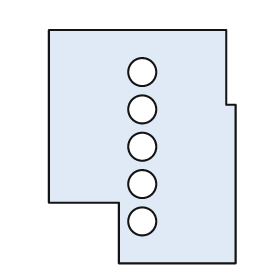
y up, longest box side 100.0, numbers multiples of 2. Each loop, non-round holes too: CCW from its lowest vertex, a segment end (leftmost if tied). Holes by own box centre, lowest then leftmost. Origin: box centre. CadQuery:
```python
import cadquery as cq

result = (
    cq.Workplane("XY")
    .moveTo(-10.0, -50.0)
    .lineTo(40.0, -50.0)
    .lineTo(40.0, 18.0)
    .lineTo(36.0, 18.0)
    .lineTo(36.0, 50.0)
    .lineTo(-40.0, 50.0)
    .lineTo(-40.0, -24.0)
    .lineTo(-10.0, -24.0)
    .close()
    .moveTo(0.0, -32.0)
    .circle(6.0)
    .moveTo(0.0, -16.0)
    .circle(6.0)
    .moveTo(0.0, 0.0)
    .circle(6.0)
    .moveTo(0.0, 16.0)
    .circle(6.0)
    .moveTo(0.0, 32.0)
    .circle(6.0)
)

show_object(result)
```